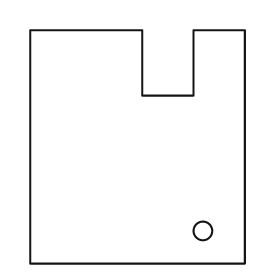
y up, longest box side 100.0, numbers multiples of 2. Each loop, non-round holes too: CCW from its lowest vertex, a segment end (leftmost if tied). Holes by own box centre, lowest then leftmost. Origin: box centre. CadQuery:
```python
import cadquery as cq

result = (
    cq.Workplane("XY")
    .moveTo(-46.0, -50.0)
    .lineTo(46.0, -50.0)
    .lineTo(46.0, 50.0)
    .lineTo(24.0, 50.0)
    .lineTo(24.0, 22.0)
    .lineTo(2.0, 22.0)
    .lineTo(2.0, 50.0)
    .lineTo(-46.0, 50.0)
    .close()
    .moveTo(28.0, -36.0)
    .circle(4.0)
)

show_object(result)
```